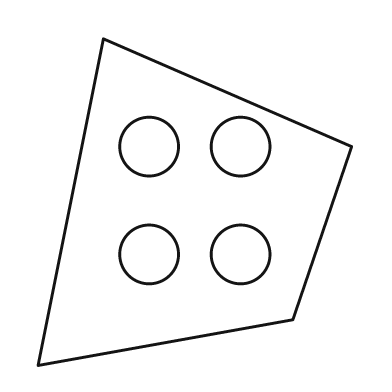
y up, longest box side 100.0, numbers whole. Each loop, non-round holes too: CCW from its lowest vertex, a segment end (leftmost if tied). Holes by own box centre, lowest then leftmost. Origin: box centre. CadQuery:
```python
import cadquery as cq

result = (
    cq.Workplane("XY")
    .moveTo(-48.0, -50.0)
    .lineTo(30.0, -36.0)
    .lineTo(48.0, 17.0)
    .lineTo(-28.0, 50.0)
    .close()
    .moveTo(-14.0, -16.0)
    .circle(9.0)
    .moveTo(14.0, -16.0)
    .circle(9.0)
    .moveTo(-14.0, 17.0)
    .circle(9.0)
    .moveTo(14.0, 17.0)
    .circle(9.0)
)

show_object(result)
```